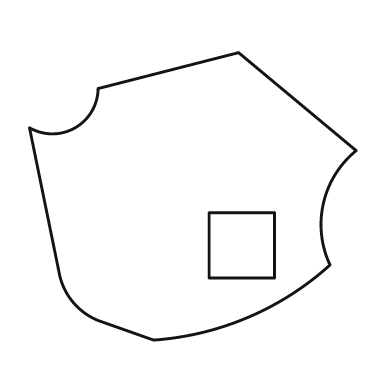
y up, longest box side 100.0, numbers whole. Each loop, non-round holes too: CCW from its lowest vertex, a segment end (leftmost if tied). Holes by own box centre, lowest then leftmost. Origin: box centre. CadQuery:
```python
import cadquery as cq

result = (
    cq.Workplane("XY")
    .moveTo(-12.0, -44.0)
    .threePointArc((17.0, -37.0), (42.0, -21.0))
    .threePointArc((40.0, -2.0), (50.0, 14.0))
    .lineTo(14.0, 44.0)
    .lineTo(-29.0, 33.0)
    .threePointArc((-36.0, 21.0), (-50.0, 21.0))
    .lineTo(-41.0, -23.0)
    .threePointArc((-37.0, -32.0), (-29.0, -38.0))
    .close()
    .moveTo(5.0, -25.0)
    .lineTo(25.0, -25.0)
    .lineTo(25.0, -5.0)
    .lineTo(5.0, -5.0)
    .close()
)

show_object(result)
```